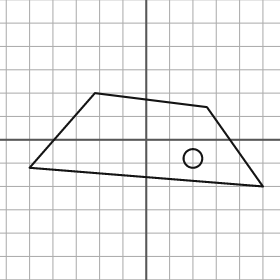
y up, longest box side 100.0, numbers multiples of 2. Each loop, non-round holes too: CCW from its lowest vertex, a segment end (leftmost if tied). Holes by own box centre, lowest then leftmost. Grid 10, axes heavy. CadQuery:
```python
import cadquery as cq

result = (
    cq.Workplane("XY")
    .moveTo(50.0, -20.0)
    .lineTo(26.0, 14.0)
    .lineTo(-22.0, 20.0)
    .lineTo(-50.0, -12.0)
    .close()
    .moveTo(20.0, -8.0)
    .circle(4.0)
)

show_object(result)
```